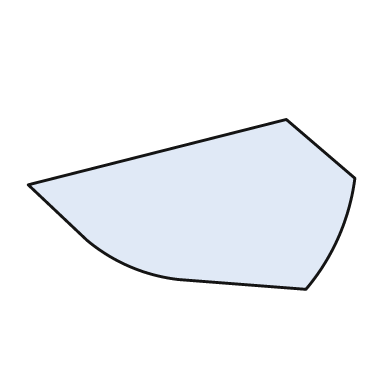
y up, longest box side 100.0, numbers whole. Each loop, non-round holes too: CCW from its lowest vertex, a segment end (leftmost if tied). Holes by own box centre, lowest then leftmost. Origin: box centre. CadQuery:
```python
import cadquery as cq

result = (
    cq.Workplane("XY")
    .moveTo(35.0, -26.0)
    .threePointArc((45.0, -10.0), (50.0, 8.0))
    .lineTo(29.0, 26.0)
    .lineTo(-50.0, 6.0)
    .lineTo(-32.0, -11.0)
    .threePointArc((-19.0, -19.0), (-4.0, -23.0))
    .close()
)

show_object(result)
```